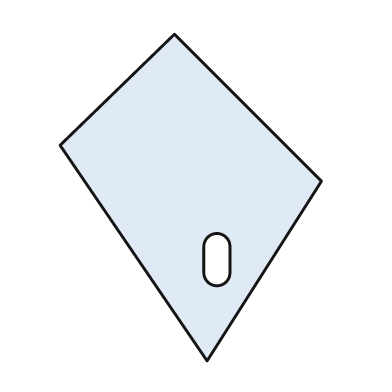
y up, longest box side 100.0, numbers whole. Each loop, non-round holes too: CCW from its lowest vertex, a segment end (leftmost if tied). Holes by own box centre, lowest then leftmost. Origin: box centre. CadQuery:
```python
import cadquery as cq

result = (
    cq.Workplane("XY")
    .moveTo(5.0, -50.0)
    .lineTo(40.0, 5.0)
    .lineTo(-5.0, 50.0)
    .lineTo(-40.0, 16.0)
    .close()
    .moveTo(4.0, -23.0)
    .threePointArc((8.0, -27.0), (12.0, -23.0))
    .lineTo(12.0, -15.0)
    .threePointArc((8.0, -11.0), (4.0, -15.0))
    .close()
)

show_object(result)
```